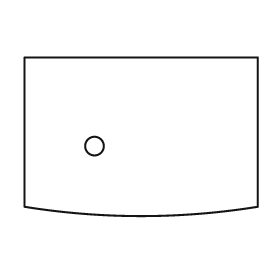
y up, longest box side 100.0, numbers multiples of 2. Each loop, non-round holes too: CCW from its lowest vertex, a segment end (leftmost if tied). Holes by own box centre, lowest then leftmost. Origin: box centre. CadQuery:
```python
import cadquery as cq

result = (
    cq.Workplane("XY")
    .moveTo(-50.0, -30.0)
    .threePointArc((0.0, -34.0), (50.0, -30.0))
    .lineTo(50.0, 34.0)
    .lineTo(-50.0, 34.0)
    .close()
    .moveTo(-20.0, -4.0)
    .circle(4.0)
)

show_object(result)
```